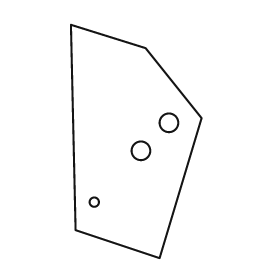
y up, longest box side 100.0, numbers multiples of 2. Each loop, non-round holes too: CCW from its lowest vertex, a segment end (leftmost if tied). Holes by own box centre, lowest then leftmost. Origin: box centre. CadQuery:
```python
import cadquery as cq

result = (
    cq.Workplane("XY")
    .moveTo(10.0, -50.0)
    .lineTo(28.0, 10.0)
    .lineTo(4.0, 40.0)
    .lineTo(-28.0, 50.0)
    .lineTo(-26.0, -38.0)
    .close()
    .moveTo(-18.0, -26.0)
    .circle(2.0)
    .moveTo(2.0, -4.0)
    .circle(4.0)
    .moveTo(14.0, 8.0)
    .circle(4.0)
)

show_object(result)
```